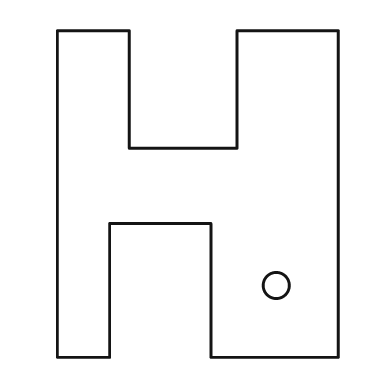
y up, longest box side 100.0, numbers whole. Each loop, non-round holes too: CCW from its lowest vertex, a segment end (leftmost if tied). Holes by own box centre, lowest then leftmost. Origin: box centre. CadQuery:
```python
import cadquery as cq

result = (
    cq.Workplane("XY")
    .moveTo(-43.0, -50.0)
    .lineTo(-27.0, -50.0)
    .lineTo(-27.0, -9.0)
    .lineTo(4.0, -9.0)
    .lineTo(4.0, -50.0)
    .lineTo(43.0, -50.0)
    .lineTo(43.0, 50.0)
    .lineTo(12.0, 50.0)
    .lineTo(12.0, 14.0)
    .lineTo(-21.0, 14.0)
    .lineTo(-21.0, 50.0)
    .lineTo(-43.0, 50.0)
    .close()
    .moveTo(24.0, -28.0)
    .circle(4.0)
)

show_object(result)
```